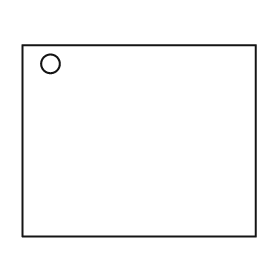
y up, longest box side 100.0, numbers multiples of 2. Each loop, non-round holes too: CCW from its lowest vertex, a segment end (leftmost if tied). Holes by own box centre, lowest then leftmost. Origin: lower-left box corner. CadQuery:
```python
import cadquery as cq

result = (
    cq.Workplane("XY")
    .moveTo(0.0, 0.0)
    .lineTo(100.0, 0.0)
    .lineTo(100.0, 82.0)
    .lineTo(0.0, 82.0)
    .close()
    .moveTo(12.0, 74.0)
    .circle(4.0)
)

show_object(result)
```